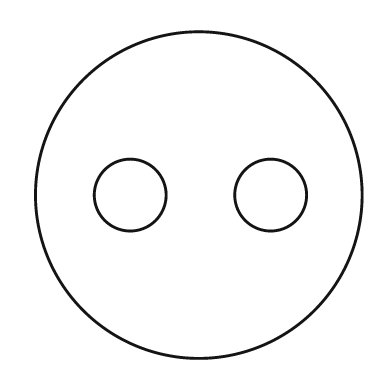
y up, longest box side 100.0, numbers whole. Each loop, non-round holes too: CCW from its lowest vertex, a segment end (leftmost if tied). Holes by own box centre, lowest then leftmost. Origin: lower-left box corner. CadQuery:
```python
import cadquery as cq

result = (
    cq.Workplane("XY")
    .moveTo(50.0, 50.0)
    .circle(50.0)
    .moveTo(29.0, 50.0)
    .circle(11.0)
    .moveTo(72.0, 50.0)
    .circle(11.0)
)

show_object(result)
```